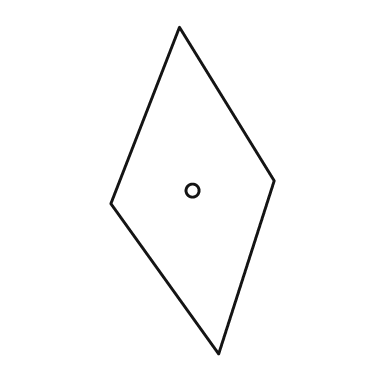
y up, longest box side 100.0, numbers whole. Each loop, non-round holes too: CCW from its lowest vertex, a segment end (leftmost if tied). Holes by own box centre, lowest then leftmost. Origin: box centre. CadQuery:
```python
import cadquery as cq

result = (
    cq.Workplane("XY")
    .moveTo(8.0, -50.0)
    .lineTo(25.0, 3.0)
    .lineTo(-4.0, 50.0)
    .lineTo(-25.0, -4.0)
    .close()
    .moveTo(0.0, 0.0)
    .circle(2.0)
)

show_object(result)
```